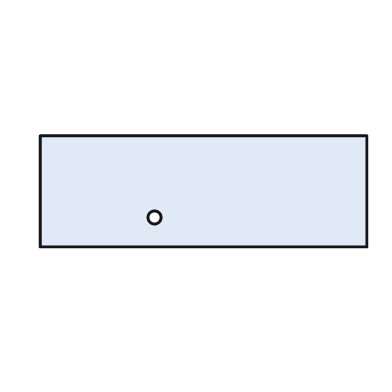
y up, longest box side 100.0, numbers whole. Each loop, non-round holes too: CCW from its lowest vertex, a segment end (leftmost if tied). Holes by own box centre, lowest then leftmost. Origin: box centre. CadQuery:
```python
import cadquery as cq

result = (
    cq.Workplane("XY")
    .moveTo(-50.0, -17.0)
    .lineTo(50.0, -17.0)
    .lineTo(50.0, 17.0)
    .lineTo(-50.0, 17.0)
    .close()
    .moveTo(-15.0, -8.0)
    .circle(2.0)
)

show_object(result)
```